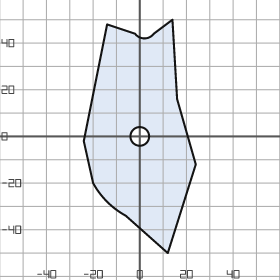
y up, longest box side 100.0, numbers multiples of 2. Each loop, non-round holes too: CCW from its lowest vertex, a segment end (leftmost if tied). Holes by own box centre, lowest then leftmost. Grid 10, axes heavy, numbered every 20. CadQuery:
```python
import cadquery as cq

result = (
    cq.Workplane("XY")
    .moveTo(12.0, -50.0)
    .lineTo(24.0, -12.0)
    .lineTo(16.0, 16.0)
    .lineTo(14.0, 50.0)
    .lineTo(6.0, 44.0)
    .threePointArc((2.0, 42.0), (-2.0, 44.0))
    .lineTo(-14.0, 48.0)
    .lineTo(-24.0, -2.0)
    .lineTo(-20.0, -20.0)
    .threePointArc((-14.0, -28.0), (-6.0, -34.0))
    .close()
    .moveTo(0.0, 0.0)
    .circle(4.0)
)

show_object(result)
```